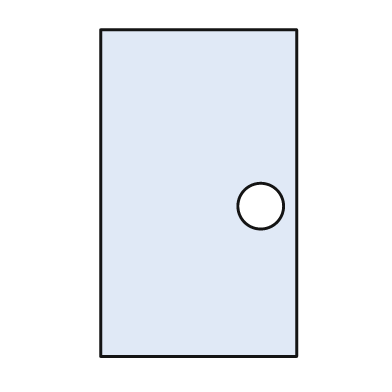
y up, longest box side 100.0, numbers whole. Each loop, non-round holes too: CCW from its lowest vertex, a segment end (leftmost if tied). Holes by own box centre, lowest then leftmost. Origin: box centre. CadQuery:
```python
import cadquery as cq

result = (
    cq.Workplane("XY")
    .moveTo(-30.0, -50.0)
    .lineTo(30.0, -50.0)
    .lineTo(30.0, 50.0)
    .lineTo(-30.0, 50.0)
    .close()
    .moveTo(19.0, -4.0)
    .circle(7.0)
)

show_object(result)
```